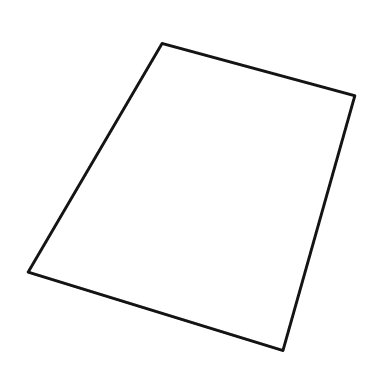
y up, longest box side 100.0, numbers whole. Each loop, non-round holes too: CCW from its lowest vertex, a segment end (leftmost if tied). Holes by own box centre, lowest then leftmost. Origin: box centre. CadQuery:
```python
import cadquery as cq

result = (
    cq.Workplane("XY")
    .moveTo(28.0, -47.0)
    .lineTo(50.0, 31.0)
    .lineTo(-9.0, 47.0)
    .lineTo(-50.0, -23.0)
    .close()
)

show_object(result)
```